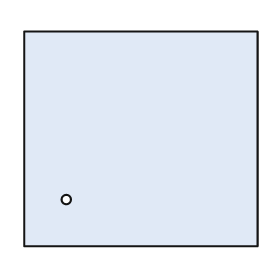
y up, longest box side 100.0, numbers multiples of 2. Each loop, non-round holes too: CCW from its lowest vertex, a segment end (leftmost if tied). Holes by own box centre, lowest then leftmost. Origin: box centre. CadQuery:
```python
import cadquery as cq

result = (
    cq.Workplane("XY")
    .moveTo(-50.0, -46.0)
    .lineTo(50.0, -46.0)
    .lineTo(50.0, 46.0)
    .lineTo(-50.0, 46.0)
    .close()
    .moveTo(-32.0, -26.0)
    .circle(2.0)
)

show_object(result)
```